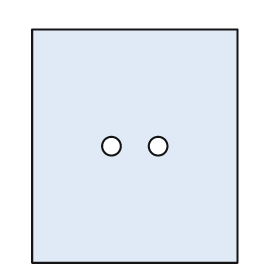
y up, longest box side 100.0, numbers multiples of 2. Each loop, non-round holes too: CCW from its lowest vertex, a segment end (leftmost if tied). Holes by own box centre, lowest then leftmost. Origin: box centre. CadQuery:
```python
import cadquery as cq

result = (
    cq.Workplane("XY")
    .moveTo(-44.0, -50.0)
    .lineTo(44.0, -50.0)
    .lineTo(44.0, 50.0)
    .lineTo(-44.0, 50.0)
    .close()
    .moveTo(-10.0, 0.0)
    .circle(4.0)
    .moveTo(10.0, 0.0)
    .circle(4.0)
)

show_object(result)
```